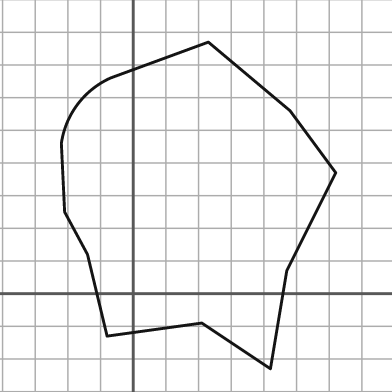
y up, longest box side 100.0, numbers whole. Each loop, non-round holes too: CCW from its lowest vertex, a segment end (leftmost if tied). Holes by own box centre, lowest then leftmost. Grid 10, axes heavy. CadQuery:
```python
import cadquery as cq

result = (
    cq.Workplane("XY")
    .moveTo(42.0, -23.0)
    .lineTo(47.0, 7.0)
    .lineTo(62.0, 37.0)
    .lineTo(48.0, 56.0)
    .lineTo(23.0, 77.0)
    .lineTo(-7.0, 66.0)
    .threePointArc((-17.0, 58.0), (-22.0, 46.0))
    .lineTo(-21.0, 25.0)
    .lineTo(-14.0, 12.0)
    .lineTo(-8.0, -13.0)
    .lineTo(21.0, -9.0)
    .close()
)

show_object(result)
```